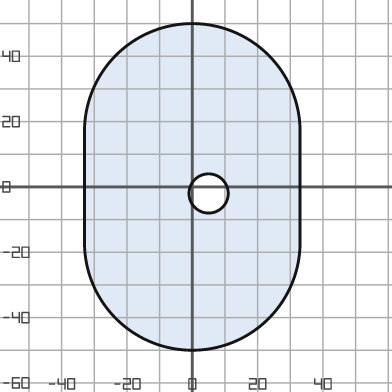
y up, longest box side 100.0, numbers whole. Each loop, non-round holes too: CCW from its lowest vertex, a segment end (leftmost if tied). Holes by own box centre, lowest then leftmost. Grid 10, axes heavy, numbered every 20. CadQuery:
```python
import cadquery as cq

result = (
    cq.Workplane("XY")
    .moveTo(-33.0, -17.0)
    .threePointArc((0.0, -50.0), (33.0, -17.0))
    .lineTo(33.0, 17.0)
    .threePointArc((0.0, 50.0), (-33.0, 17.0))
    .close()
    .moveTo(5.0, -2.0)
    .circle(6.0)
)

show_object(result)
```